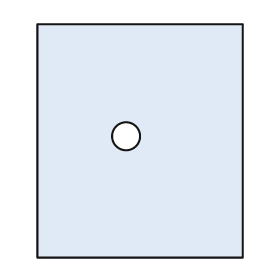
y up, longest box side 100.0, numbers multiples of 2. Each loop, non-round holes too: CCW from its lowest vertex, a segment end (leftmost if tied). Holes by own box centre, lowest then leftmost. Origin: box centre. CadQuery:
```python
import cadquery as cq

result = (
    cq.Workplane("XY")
    .moveTo(-44.0, -50.0)
    .lineTo(44.0, -50.0)
    .lineTo(44.0, 50.0)
    .lineTo(-44.0, 50.0)
    .close()
    .moveTo(-6.0, 2.0)
    .circle(6.0)
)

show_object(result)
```